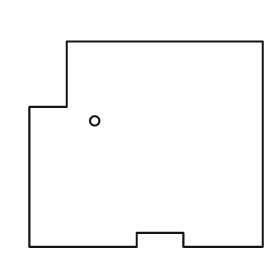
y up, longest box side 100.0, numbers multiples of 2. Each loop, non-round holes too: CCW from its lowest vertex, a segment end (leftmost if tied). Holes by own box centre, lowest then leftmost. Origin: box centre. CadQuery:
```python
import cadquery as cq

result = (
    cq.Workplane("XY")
    .moveTo(-50.0, -44.0)
    .lineTo(-4.0, -44.0)
    .lineTo(-4.0, -38.0)
    .lineTo(16.0, -38.0)
    .lineTo(16.0, -44.0)
    .lineTo(50.0, -44.0)
    .lineTo(50.0, 44.0)
    .lineTo(-34.0, 44.0)
    .lineTo(-34.0, 16.0)
    .lineTo(-50.0, 16.0)
    .close()
    .moveTo(-22.0, 10.0)
    .circle(2.0)
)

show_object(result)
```